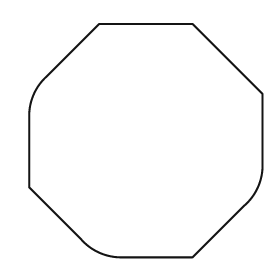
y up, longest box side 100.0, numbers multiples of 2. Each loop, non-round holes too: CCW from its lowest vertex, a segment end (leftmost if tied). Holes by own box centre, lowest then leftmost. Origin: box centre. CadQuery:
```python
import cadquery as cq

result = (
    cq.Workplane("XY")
    .moveTo(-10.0, -50.0)
    .lineTo(20.0, -50.0)
    .lineTo(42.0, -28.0)
    .threePointArc((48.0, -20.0), (50.0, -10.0))
    .lineTo(50.0, 20.0)
    .lineTo(20.0, 50.0)
    .lineTo(-20.0, 50.0)
    .lineTo(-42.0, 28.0)
    .threePointArc((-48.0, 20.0), (-50.0, 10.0))
    .lineTo(-50.0, -20.0)
    .lineTo(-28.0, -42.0)
    .threePointArc((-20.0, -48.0), (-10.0, -50.0))
    .close()
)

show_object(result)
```